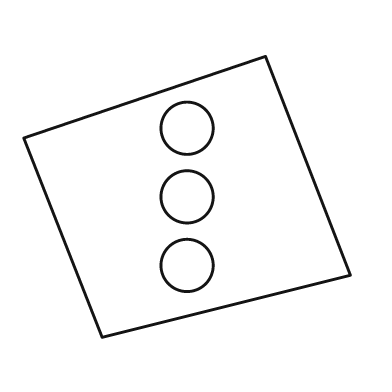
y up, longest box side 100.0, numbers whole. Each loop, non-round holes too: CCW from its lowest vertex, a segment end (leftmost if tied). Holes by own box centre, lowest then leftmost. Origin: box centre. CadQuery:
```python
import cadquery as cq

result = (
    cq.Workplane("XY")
    .moveTo(-26.0, -43.0)
    .lineTo(50.0, -24.0)
    .lineTo(24.0, 43.0)
    .lineTo(-50.0, 18.0)
    .close()
    .moveTo(0.0, -21.0)
    .circle(8.0)
    .moveTo(0.0, 0.0)
    .circle(8.0)
    .moveTo(0.0, 21.0)
    .circle(8.0)
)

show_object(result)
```